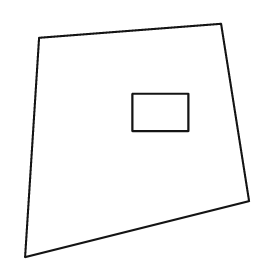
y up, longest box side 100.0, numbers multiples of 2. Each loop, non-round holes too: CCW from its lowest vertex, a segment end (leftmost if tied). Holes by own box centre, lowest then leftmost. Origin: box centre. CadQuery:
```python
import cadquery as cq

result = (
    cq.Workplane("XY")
    .moveTo(-48.0, -50.0)
    .lineTo(48.0, -26.0)
    .lineTo(36.0, 50.0)
    .lineTo(-42.0, 44.0)
    .close()
    .moveTo(-2.0, 4.0)
    .lineTo(22.0, 4.0)
    .lineTo(22.0, 20.0)
    .lineTo(-2.0, 20.0)
    .close()
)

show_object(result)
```